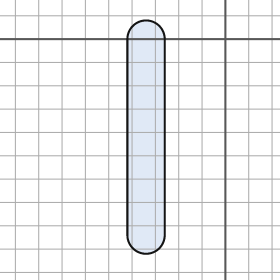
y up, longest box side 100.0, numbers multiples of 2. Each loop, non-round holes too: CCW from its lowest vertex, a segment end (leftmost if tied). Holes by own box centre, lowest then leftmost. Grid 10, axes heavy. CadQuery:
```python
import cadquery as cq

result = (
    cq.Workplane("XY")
    .moveTo(-42.0, -84.0)
    .threePointArc((-34.0, -92.0), (-26.0, -84.0))
    .lineTo(-26.0, 0.0)
    .threePointArc((-34.0, 8.0), (-42.0, 0.0))
    .close()
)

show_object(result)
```